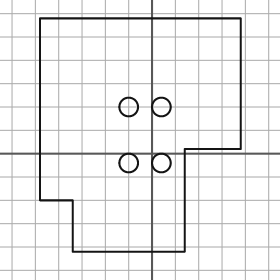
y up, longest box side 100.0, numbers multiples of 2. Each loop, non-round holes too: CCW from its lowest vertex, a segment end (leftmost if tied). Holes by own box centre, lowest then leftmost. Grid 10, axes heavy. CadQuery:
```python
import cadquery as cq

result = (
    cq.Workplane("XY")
    .moveTo(-34.0, -42.0)
    .lineTo(14.0, -42.0)
    .lineTo(14.0, 2.0)
    .lineTo(38.0, 2.0)
    .lineTo(38.0, 58.0)
    .lineTo(-48.0, 58.0)
    .lineTo(-48.0, -20.0)
    .lineTo(-34.0, -20.0)
    .close()
    .moveTo(-10.0, -4.0)
    .circle(4.0)
    .moveTo(4.0, -4.0)
    .circle(4.0)
    .moveTo(-10.0, 20.0)
    .circle(4.0)
    .moveTo(4.0, 20.0)
    .circle(4.0)
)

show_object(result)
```